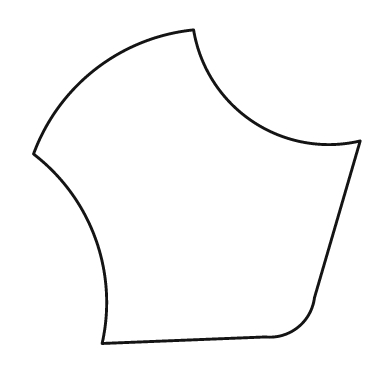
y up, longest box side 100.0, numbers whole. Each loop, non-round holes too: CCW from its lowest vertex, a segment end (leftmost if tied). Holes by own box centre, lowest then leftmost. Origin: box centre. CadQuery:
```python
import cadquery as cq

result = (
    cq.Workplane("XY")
    .moveTo(-29.0, -48.0)
    .lineTo(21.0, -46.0)
    .threePointArc((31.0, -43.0), (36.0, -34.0))
    .lineTo(50.0, 14.0)
    .threePointArc((17.0, 20.0), (-1.0, 48.0))
    .threePointArc((-31.0, 36.0), (-50.0, 10.0))
    .threePointArc((-31.0, -16.0), (-29.0, -48.0))
    .close()
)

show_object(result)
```